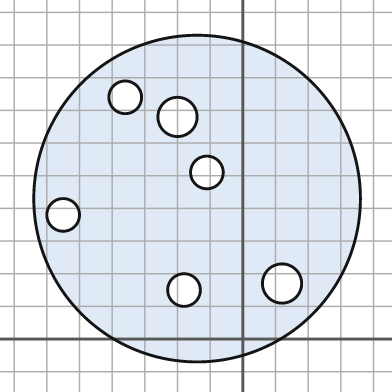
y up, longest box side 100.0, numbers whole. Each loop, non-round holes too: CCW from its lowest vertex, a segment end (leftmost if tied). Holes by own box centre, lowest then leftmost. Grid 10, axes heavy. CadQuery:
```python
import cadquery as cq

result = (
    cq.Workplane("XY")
    .moveTo(-14.0, 43.0)
    .circle(50.0)
    .moveTo(-18.0, 15.0)
    .circle(5.0)
    .moveTo(12.0, 17.0)
    .circle(6.0)
    .moveTo(-55.0, 38.0)
    .circle(5.0)
    .moveTo(-11.0, 51.0)
    .circle(5.0)
    .moveTo(-20.0, 68.0)
    .circle(6.0)
    .moveTo(-36.0, 74.0)
    .circle(5.0)
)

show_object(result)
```